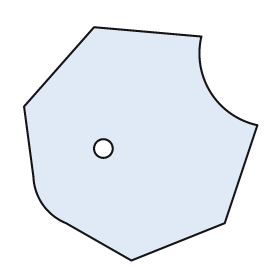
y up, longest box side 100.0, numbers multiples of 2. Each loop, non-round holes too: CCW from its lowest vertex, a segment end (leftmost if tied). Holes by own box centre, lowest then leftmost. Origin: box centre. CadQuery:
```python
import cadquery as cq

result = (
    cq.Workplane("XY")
    .moveTo(-4.0, -50.0)
    .lineTo(36.0, -34.0)
    .lineTo(50.0, 8.0)
    .threePointArc((30.0, 22.0), (26.0, 46.0))
    .lineTo(-20.0, 50.0)
    .lineTo(-50.0, 16.0)
    .lineTo(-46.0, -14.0)
    .threePointArc((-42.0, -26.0), (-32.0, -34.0))
    .close()
    .moveTo(-16.0, -2.0)
    .circle(4.0)
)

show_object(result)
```